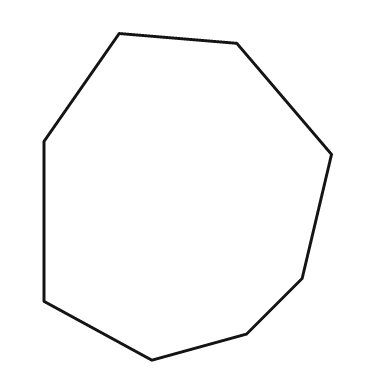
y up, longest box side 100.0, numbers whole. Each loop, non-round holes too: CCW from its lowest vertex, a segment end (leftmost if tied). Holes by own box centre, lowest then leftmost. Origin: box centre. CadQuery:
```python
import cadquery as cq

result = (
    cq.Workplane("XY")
    .moveTo(-11.0, -50.0)
    .lineTo(18.0, -42.0)
    .lineTo(35.0, -25.0)
    .lineTo(44.0, 13.0)
    .lineTo(15.0, 47.0)
    .lineTo(-21.0, 50.0)
    .lineTo(-44.0, 17.0)
    .lineTo(-44.0, -32.0)
    .close()
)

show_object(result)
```